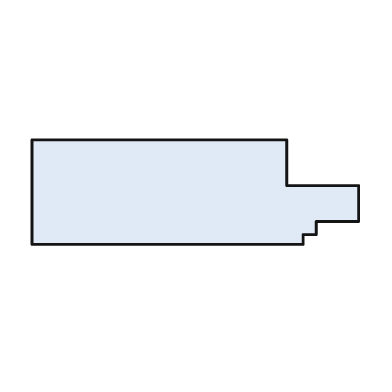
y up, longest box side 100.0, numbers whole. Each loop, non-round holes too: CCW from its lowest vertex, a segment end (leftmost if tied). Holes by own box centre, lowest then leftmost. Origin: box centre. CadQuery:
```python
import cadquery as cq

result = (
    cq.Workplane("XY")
    .moveTo(-50.0, -16.0)
    .lineTo(33.0, -16.0)
    .lineTo(33.0, -13.0)
    .lineTo(37.0, -13.0)
    .lineTo(37.0, -9.0)
    .lineTo(50.0, -9.0)
    .lineTo(50.0, 2.0)
    .lineTo(28.0, 2.0)
    .lineTo(28.0, 16.0)
    .lineTo(-50.0, 16.0)
    .close()
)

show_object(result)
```